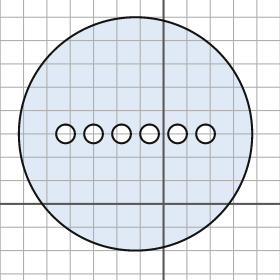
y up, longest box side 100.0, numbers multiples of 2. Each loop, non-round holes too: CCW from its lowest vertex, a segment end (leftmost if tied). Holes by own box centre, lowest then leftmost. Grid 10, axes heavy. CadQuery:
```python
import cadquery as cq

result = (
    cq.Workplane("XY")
    .moveTo(-12.0, 30.0)
    .circle(50.0)
    .moveTo(-42.0, 30.0)
    .circle(4.0)
    .moveTo(-30.0, 30.0)
    .circle(4.0)
    .moveTo(-18.0, 30.0)
    .circle(4.0)
    .moveTo(-6.0, 30.0)
    .circle(4.0)
    .moveTo(6.0, 30.0)
    .circle(4.0)
    .moveTo(18.0, 30.0)
    .circle(4.0)
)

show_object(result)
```